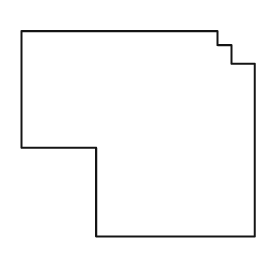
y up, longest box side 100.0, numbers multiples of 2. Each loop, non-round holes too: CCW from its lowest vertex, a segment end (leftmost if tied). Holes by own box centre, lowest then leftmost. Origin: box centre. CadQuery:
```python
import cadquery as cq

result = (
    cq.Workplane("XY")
    .moveTo(-18.0, -44.0)
    .lineTo(50.0, -44.0)
    .lineTo(50.0, 30.0)
    .lineTo(40.0, 30.0)
    .lineTo(40.0, 38.0)
    .lineTo(34.0, 38.0)
    .lineTo(34.0, 44.0)
    .lineTo(-50.0, 44.0)
    .lineTo(-50.0, -6.0)
    .lineTo(-18.0, -6.0)
    .close()
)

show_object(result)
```